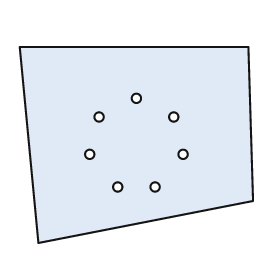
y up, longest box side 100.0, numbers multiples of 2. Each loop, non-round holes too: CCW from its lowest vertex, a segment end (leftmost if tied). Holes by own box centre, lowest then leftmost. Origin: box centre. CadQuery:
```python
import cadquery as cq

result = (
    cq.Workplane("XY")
    .moveTo(-42.0, -42.0)
    .lineTo(50.0, -24.0)
    .lineTo(48.0, 42.0)
    .lineTo(-50.0, 42.0)
    .close()
    .moveTo(-8.0, -18.0)
    .circle(2.0)
    .moveTo(8.0, -18.0)
    .circle(2.0)
    .moveTo(-20.0, -4.0)
    .circle(2.0)
    .moveTo(20.0, -4.0)
    .circle(2.0)
    .moveTo(-16.0, 12.0)
    .circle(2.0)
    .moveTo(16.0, 12.0)
    .circle(2.0)
    .moveTo(0.0, 20.0)
    .circle(2.0)
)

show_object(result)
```